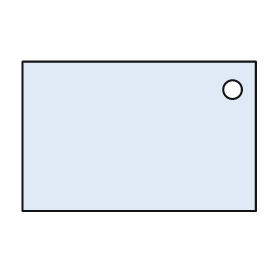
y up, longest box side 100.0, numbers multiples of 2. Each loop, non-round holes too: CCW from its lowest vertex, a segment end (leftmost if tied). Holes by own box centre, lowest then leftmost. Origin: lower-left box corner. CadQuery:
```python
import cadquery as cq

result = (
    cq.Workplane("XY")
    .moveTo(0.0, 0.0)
    .lineTo(100.0, 0.0)
    .lineTo(100.0, 64.0)
    .lineTo(0.0, 64.0)
    .close()
    .moveTo(90.0, 52.0)
    .circle(4.0)
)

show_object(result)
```